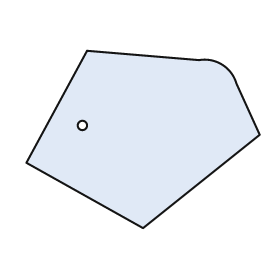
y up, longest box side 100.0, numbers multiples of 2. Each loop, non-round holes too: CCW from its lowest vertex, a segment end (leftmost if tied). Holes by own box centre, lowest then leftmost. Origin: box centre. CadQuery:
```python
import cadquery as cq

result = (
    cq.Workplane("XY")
    .moveTo(0.0, -38.0)
    .lineTo(50.0, 2.0)
    .lineTo(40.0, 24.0)
    .threePointArc((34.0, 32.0), (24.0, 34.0))
    .lineTo(-24.0, 38.0)
    .lineTo(-50.0, -10.0)
    .close()
    .moveTo(-26.0, 6.0)
    .circle(2.0)
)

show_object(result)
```